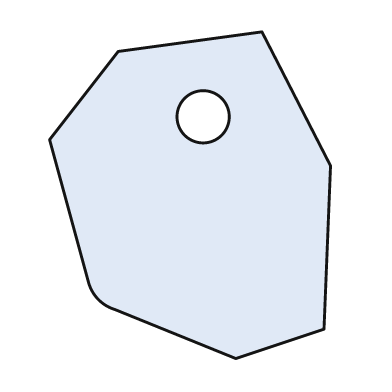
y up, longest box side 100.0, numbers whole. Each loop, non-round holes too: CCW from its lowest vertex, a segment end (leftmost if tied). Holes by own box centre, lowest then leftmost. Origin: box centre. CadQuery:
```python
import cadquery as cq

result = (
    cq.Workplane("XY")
    .moveTo(14.0, -50.0)
    .lineTo(41.0, -41.0)
    .lineTo(43.0, 9.0)
    .lineTo(22.0, 50.0)
    .lineTo(-22.0, 44.0)
    .lineTo(-43.0, 17.0)
    .lineTo(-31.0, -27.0)
    .threePointArc((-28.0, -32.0), (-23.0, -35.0))
    .close()
    .moveTo(4.0, 24.0)
    .circle(8.0)
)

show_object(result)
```